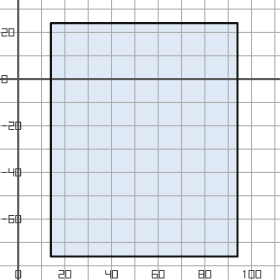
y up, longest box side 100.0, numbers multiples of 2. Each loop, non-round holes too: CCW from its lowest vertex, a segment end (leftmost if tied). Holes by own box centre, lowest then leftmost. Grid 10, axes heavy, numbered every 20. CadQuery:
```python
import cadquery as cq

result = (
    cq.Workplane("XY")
    .moveTo(14.0, -76.0)
    .lineTo(94.0, -76.0)
    .lineTo(94.0, 24.0)
    .lineTo(14.0, 24.0)
    .close()
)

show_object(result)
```